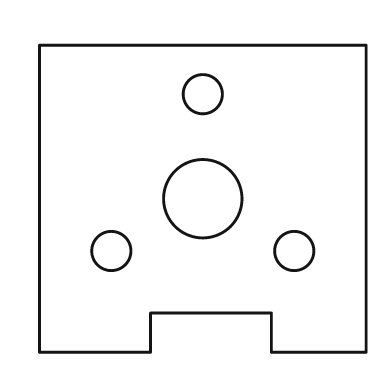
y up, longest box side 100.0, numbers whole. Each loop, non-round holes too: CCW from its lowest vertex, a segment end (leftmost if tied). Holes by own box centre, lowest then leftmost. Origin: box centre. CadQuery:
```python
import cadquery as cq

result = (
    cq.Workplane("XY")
    .moveTo(-50.0, -47.0)
    .lineTo(-16.0, -47.0)
    .lineTo(-16.0, -35.0)
    .lineTo(21.0, -35.0)
    .lineTo(21.0, -47.0)
    .lineTo(50.0, -47.0)
    .lineTo(50.0, 47.0)
    .lineTo(-50.0, 47.0)
    .close()
    .moveTo(-28.0, -16.0)
    .circle(6.0)
    .moveTo(28.0, -16.0)
    .circle(6.0)
    .moveTo(0.0, 0.0)
    .circle(12.0)
    .moveTo(0.0, 32.0)
    .circle(6.0)
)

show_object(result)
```